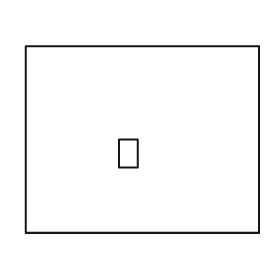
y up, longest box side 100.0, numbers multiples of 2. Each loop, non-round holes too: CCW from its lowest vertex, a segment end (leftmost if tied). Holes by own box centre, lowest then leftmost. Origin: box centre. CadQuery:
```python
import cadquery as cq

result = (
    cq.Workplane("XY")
    .moveTo(-50.0, -40.0)
    .lineTo(50.0, -40.0)
    .lineTo(50.0, 40.0)
    .lineTo(-50.0, 40.0)
    .close()
    .moveTo(-10.0, -12.0)
    .lineTo(-2.0, -12.0)
    .lineTo(-2.0, 0.0)
    .lineTo(-10.0, 0.0)
    .close()
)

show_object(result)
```